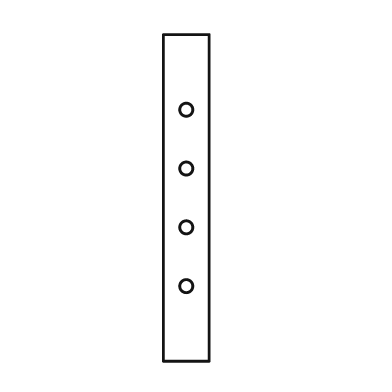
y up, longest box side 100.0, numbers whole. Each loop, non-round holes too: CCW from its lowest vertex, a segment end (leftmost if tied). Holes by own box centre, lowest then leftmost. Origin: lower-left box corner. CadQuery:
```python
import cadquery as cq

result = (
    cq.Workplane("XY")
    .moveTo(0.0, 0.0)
    .lineTo(14.0, 0.0)
    .lineTo(14.0, 100.0)
    .lineTo(0.0, 100.0)
    .close()
    .moveTo(7.0, 23.0)
    .circle(2.0)
    .moveTo(7.0, 41.0)
    .circle(2.0)
    .moveTo(7.0, 59.0)
    .circle(2.0)
    .moveTo(7.0, 77.0)
    .circle(2.0)
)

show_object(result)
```